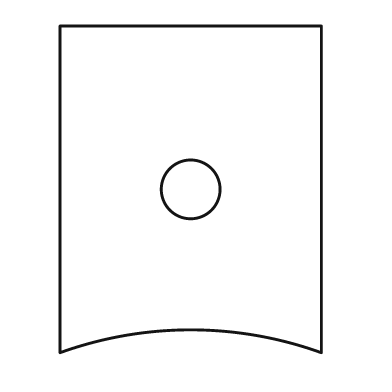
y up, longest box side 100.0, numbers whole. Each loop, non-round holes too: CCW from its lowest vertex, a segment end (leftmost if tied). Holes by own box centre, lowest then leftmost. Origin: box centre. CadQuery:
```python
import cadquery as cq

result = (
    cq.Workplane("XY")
    .moveTo(-40.0, -50.0)
    .threePointArc((0.0, -43.0), (40.0, -50.0))
    .lineTo(40.0, 50.0)
    .lineTo(-40.0, 50.0)
    .close()
    .moveTo(0.0, 0.0)
    .circle(9.0)
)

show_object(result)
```